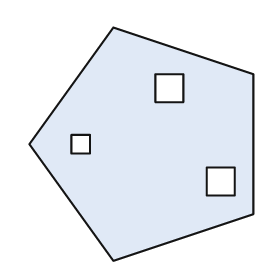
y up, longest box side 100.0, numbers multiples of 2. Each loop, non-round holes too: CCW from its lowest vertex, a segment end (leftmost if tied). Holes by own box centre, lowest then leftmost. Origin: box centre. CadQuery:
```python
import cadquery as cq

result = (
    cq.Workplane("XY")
    .moveTo(-12.0, -50.0)
    .lineTo(48.0, -30.0)
    .lineTo(48.0, 30.0)
    .lineTo(-12.0, 50.0)
    .lineTo(-48.0, 0.0)
    .close()
    .moveTo(28.0, -22.0)
    .lineTo(40.0, -22.0)
    .lineTo(40.0, -10.0)
    .lineTo(28.0, -10.0)
    .close()
    .moveTo(-30.0, -4.0)
    .lineTo(-22.0, -4.0)
    .lineTo(-22.0, 4.0)
    .lineTo(-30.0, 4.0)
    .close()
    .moveTo(6.0, 18.0)
    .lineTo(18.0, 18.0)
    .lineTo(18.0, 30.0)
    .lineTo(6.0, 30.0)
    .close()
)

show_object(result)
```